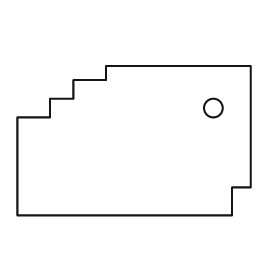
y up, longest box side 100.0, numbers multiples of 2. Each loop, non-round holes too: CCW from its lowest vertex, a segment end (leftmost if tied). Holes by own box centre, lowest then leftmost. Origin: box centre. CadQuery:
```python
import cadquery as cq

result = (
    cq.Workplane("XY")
    .moveTo(-50.0, -32.0)
    .lineTo(42.0, -32.0)
    .lineTo(42.0, -20.0)
    .lineTo(50.0, -20.0)
    .lineTo(50.0, 32.0)
    .lineTo(-12.0, 32.0)
    .lineTo(-12.0, 26.0)
    .lineTo(-26.0, 26.0)
    .lineTo(-26.0, 18.0)
    .lineTo(-36.0, 18.0)
    .lineTo(-36.0, 10.0)
    .lineTo(-50.0, 10.0)
    .close()
    .moveTo(34.0, 14.0)
    .circle(4.0)
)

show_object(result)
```